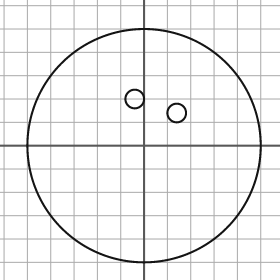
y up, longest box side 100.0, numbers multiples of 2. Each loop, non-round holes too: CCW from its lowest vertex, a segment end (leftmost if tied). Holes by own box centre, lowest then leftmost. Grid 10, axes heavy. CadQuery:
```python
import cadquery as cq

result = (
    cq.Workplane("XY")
    .moveTo(0.0, 0.0)
    .circle(50.0)
    .moveTo(14.0, 14.0)
    .circle(4.0)
    .moveTo(-4.0, 20.0)
    .circle(4.0)
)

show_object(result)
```